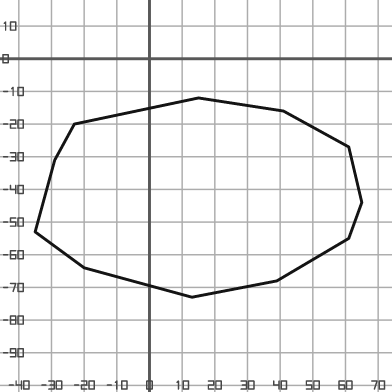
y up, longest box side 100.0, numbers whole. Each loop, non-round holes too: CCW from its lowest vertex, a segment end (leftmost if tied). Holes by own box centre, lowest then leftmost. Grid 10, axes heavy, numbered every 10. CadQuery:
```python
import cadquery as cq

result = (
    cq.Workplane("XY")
    .moveTo(13.0, -73.0)
    .lineTo(39.0, -68.0)
    .lineTo(61.0, -55.0)
    .lineTo(65.0, -44.0)
    .lineTo(61.0, -27.0)
    .lineTo(41.0, -16.0)
    .lineTo(15.0, -12.0)
    .lineTo(-23.0, -20.0)
    .lineTo(-29.0, -31.0)
    .lineTo(-35.0, -53.0)
    .lineTo(-20.0, -64.0)
    .close()
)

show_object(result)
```